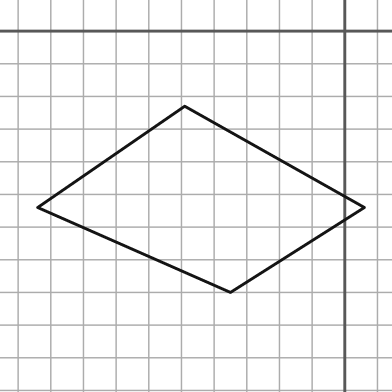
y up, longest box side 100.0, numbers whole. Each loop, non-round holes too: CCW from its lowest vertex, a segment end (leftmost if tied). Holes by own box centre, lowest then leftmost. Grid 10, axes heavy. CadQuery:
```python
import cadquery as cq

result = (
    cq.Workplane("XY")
    .moveTo(-35.0, -80.0)
    .lineTo(6.0, -54.0)
    .lineTo(-49.0, -23.0)
    .lineTo(-94.0, -54.0)
    .close()
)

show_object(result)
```